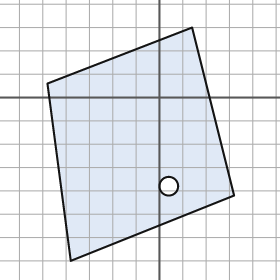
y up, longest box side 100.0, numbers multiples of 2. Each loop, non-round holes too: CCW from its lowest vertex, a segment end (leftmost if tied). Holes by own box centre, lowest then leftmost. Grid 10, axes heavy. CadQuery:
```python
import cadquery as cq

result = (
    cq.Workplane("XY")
    .moveTo(-38.0, -70.0)
    .lineTo(32.0, -42.0)
    .lineTo(14.0, 30.0)
    .lineTo(-48.0, 6.0)
    .close()
    .moveTo(4.0, -38.0)
    .circle(4.0)
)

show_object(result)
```